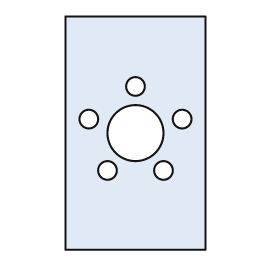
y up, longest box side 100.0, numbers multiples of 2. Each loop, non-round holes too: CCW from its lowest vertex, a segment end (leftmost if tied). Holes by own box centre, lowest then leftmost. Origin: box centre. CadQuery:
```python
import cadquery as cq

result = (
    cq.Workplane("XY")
    .moveTo(-30.0, -50.0)
    .lineTo(30.0, -50.0)
    .lineTo(30.0, 50.0)
    .lineTo(-30.0, 50.0)
    .close()
    .moveTo(-12.0, -16.0)
    .circle(4.0)
    .moveTo(12.0, -16.0)
    .circle(4.0)
    .moveTo(0.0, 0.0)
    .circle(12.0)
    .moveTo(-20.0, 6.0)
    .circle(4.0)
    .moveTo(20.0, 6.0)
    .circle(4.0)
    .moveTo(0.0, 20.0)
    .circle(4.0)
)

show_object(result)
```